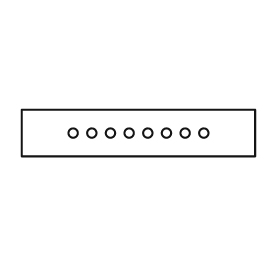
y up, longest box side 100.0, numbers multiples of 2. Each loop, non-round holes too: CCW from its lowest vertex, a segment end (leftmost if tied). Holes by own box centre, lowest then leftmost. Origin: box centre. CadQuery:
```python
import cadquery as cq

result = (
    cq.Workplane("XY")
    .moveTo(-50.0, -10.0)
    .lineTo(50.0, -10.0)
    .lineTo(50.0, 10.0)
    .lineTo(-50.0, 10.0)
    .close()
    .moveTo(-28.0, 0.0)
    .circle(2.0)
    .moveTo(-20.0, 0.0)
    .circle(2.0)
    .moveTo(-12.0, 0.0)
    .circle(2.0)
    .moveTo(-4.0, 0.0)
    .circle(2.0)
    .moveTo(4.0, 0.0)
    .circle(2.0)
    .moveTo(12.0, 0.0)
    .circle(2.0)
    .moveTo(20.0, 0.0)
    .circle(2.0)
    .moveTo(28.0, 0.0)
    .circle(2.0)
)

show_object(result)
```